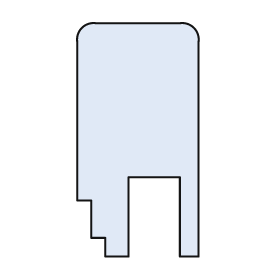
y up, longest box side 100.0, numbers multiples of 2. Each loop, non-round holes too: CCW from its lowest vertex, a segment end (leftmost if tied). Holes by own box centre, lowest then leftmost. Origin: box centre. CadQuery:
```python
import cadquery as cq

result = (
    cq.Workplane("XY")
    .moveTo(-14.0, -50.0)
    .lineTo(-4.0, -50.0)
    .lineTo(-4.0, -16.0)
    .lineTo(18.0, -16.0)
    .lineTo(18.0, -50.0)
    .lineTo(26.0, -50.0)
    .lineTo(26.0, 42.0)
    .threePointArc((24.0, 48.0), (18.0, 50.0))
    .lineTo(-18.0, 50.0)
    .threePointArc((-24.0, 48.0), (-26.0, 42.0))
    .lineTo(-26.0, -26.0)
    .lineTo(-20.0, -26.0)
    .lineTo(-20.0, -42.0)
    .lineTo(-14.0, -42.0)
    .close()
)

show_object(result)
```